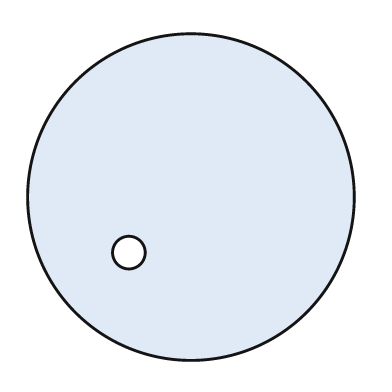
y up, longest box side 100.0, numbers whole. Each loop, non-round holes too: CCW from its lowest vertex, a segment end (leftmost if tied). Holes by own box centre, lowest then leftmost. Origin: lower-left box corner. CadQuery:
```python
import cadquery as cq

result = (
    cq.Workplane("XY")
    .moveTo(50.0, 50.0)
    .circle(50.0)
    .moveTo(31.0, 33.0)
    .circle(5.0)
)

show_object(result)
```